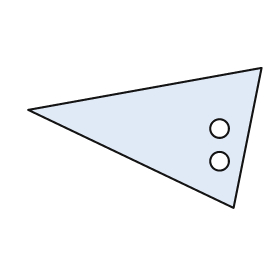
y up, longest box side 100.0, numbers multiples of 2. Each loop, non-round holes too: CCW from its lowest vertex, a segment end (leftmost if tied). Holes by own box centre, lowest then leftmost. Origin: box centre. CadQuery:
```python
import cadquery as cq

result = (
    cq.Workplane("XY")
    .moveTo(38.0, -30.0)
    .lineTo(50.0, 30.0)
    .lineTo(-50.0, 12.0)
    .close()
    .moveTo(32.0, -10.0)
    .circle(4.0)
    .moveTo(32.0, 4.0)
    .circle(4.0)
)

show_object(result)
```